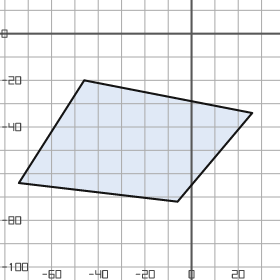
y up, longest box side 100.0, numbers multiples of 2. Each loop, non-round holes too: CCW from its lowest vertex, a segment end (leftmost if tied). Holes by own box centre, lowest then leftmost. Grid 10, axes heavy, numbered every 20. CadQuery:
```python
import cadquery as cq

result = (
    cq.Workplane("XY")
    .moveTo(-6.0, -72.0)
    .lineTo(26.0, -34.0)
    .lineTo(-46.0, -20.0)
    .lineTo(-74.0, -64.0)
    .close()
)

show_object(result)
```